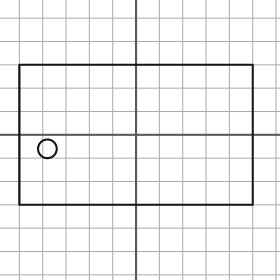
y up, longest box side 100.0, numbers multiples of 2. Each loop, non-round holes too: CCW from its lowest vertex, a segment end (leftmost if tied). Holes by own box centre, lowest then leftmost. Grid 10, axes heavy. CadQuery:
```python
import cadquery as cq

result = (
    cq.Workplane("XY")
    .moveTo(-50.0, -30.0)
    .lineTo(50.0, -30.0)
    .lineTo(50.0, 30.0)
    .lineTo(-50.0, 30.0)
    .close()
    .moveTo(-38.0, -6.0)
    .circle(4.0)
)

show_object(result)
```